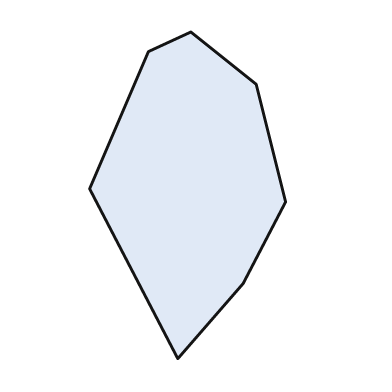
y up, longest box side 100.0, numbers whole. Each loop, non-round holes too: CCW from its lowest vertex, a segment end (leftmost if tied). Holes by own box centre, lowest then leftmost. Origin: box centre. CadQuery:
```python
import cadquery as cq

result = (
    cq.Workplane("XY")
    .moveTo(-3.0, -50.0)
    .lineTo(17.0, -27.0)
    .lineTo(30.0, -2.0)
    .lineTo(21.0, 34.0)
    .lineTo(1.0, 50.0)
    .lineTo(-12.0, 44.0)
    .lineTo(-30.0, 2.0)
    .close()
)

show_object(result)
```